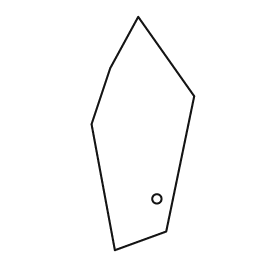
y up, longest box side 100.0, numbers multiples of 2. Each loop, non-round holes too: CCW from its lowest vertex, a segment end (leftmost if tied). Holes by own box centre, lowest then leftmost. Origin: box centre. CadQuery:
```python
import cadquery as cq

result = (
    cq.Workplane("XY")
    .moveTo(-12.0, -50.0)
    .lineTo(10.0, -42.0)
    .lineTo(22.0, 16.0)
    .lineTo(-2.0, 50.0)
    .lineTo(-14.0, 28.0)
    .lineTo(-22.0, 4.0)
    .close()
    .moveTo(6.0, -28.0)
    .circle(2.0)
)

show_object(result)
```